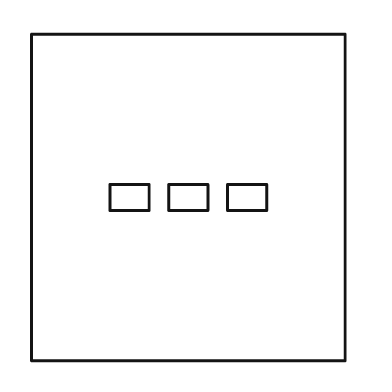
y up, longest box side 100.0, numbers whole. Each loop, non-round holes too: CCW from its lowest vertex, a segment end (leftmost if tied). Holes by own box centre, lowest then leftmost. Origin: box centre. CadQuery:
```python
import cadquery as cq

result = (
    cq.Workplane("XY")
    .moveTo(-48.0, -50.0)
    .lineTo(48.0, -50.0)
    .lineTo(48.0, 50.0)
    .lineTo(-48.0, 50.0)
    .close()
    .moveTo(-24.0, -4.0)
    .lineTo(-12.0, -4.0)
    .lineTo(-12.0, 4.0)
    .lineTo(-24.0, 4.0)
    .close()
    .moveTo(-6.0, -4.0)
    .lineTo(6.0, -4.0)
    .lineTo(6.0, 4.0)
    .lineTo(-6.0, 4.0)
    .close()
    .moveTo(12.0, -4.0)
    .lineTo(24.0, -4.0)
    .lineTo(24.0, 4.0)
    .lineTo(12.0, 4.0)
    .close()
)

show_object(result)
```